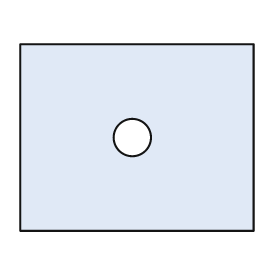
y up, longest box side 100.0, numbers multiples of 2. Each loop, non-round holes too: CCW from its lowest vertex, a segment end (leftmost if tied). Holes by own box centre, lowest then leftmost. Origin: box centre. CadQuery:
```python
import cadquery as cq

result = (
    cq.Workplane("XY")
    .moveTo(-50.0, -40.0)
    .lineTo(50.0, -40.0)
    .lineTo(50.0, 40.0)
    .lineTo(-50.0, 40.0)
    .close()
    .moveTo(-2.0, 0.0)
    .circle(8.0)
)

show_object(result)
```